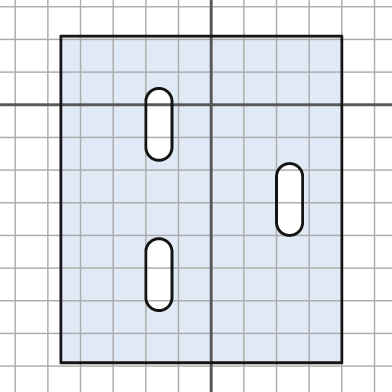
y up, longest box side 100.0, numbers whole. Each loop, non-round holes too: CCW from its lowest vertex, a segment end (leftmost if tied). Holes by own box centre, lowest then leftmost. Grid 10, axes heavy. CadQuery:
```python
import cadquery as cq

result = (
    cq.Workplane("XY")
    .moveTo(-46.0, -79.0)
    .lineTo(40.0, -79.0)
    .lineTo(40.0, 21.0)
    .lineTo(-46.0, 21.0)
    .close()
    .moveTo(-20.0, -59.0)
    .threePointArc((-16.0, -63.0), (-12.0, -59.0))
    .lineTo(-12.0, -45.0)
    .threePointArc((-16.0, -41.0), (-20.0, -45.0))
    .close()
    .moveTo(20.0, -36.0)
    .threePointArc((24.0, -40.0), (28.0, -36.0))
    .lineTo(28.0, -22.0)
    .threePointArc((24.0, -18.0), (20.0, -22.0))
    .close()
    .moveTo(-20.0, -13.0)
    .threePointArc((-16.0, -17.0), (-12.0, -13.0))
    .lineTo(-12.0, 1.0)
    .threePointArc((-16.0, 5.0), (-20.0, 1.0))
    .close()
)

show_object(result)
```